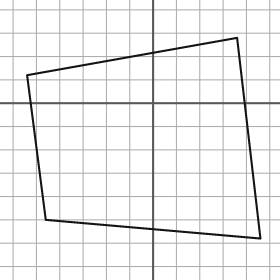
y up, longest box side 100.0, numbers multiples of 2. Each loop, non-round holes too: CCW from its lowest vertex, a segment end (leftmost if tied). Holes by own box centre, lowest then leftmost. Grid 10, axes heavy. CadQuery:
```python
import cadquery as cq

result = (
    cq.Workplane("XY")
    .moveTo(46.0, -58.0)
    .lineTo(36.0, 28.0)
    .lineTo(-54.0, 12.0)
    .lineTo(-46.0, -50.0)
    .close()
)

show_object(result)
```